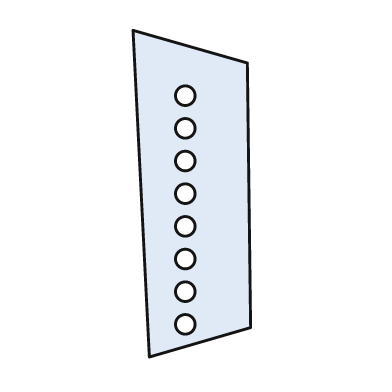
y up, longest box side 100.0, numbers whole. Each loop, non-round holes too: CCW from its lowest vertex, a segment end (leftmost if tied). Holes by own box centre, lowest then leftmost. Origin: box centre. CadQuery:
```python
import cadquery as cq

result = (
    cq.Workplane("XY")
    .moveTo(-13.0, -50.0)
    .lineTo(18.0, -41.0)
    .lineTo(17.0, 40.0)
    .lineTo(-18.0, 50.0)
    .close()
    .moveTo(-2.0, -40.0)
    .circle(3.0)
    .moveTo(-2.0, -30.0)
    .circle(3.0)
    .moveTo(-2.0, -20.0)
    .circle(3.0)
    .moveTo(-2.0, -10.0)
    .circle(3.0)
    .moveTo(-2.0, 0.0)
    .circle(3.0)
    .moveTo(-2.0, 10.0)
    .circle(3.0)
    .moveTo(-2.0, 20.0)
    .circle(3.0)
    .moveTo(-2.0, 30.0)
    .circle(3.0)
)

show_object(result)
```